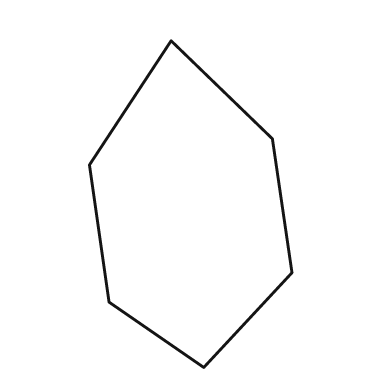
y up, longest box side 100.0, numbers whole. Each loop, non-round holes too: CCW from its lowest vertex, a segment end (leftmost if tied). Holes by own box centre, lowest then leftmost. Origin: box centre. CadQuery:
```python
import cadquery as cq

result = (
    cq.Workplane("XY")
    .moveTo(4.0, -50.0)
    .lineTo(31.0, -21.0)
    .lineTo(25.0, 20.0)
    .lineTo(-6.0, 50.0)
    .lineTo(-31.0, 12.0)
    .lineTo(-25.0, -30.0)
    .close()
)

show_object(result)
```